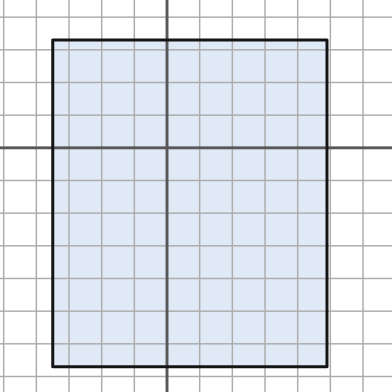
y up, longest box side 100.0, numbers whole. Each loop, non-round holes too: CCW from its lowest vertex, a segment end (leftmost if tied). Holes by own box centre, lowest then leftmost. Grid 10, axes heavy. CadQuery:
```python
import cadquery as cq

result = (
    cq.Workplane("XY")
    .moveTo(-35.0, -67.0)
    .lineTo(49.0, -67.0)
    .lineTo(49.0, 33.0)
    .lineTo(-35.0, 33.0)
    .close()
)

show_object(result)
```